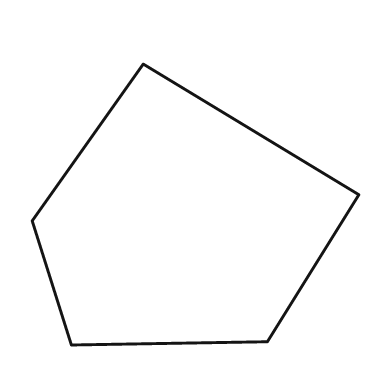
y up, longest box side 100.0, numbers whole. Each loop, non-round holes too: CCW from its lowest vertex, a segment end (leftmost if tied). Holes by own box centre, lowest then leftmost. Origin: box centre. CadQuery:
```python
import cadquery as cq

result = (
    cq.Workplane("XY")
    .moveTo(-38.0, -43.0)
    .lineTo(22.0, -42.0)
    .lineTo(50.0, 3.0)
    .lineTo(-16.0, 43.0)
    .lineTo(-50.0, -5.0)
    .close()
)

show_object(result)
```